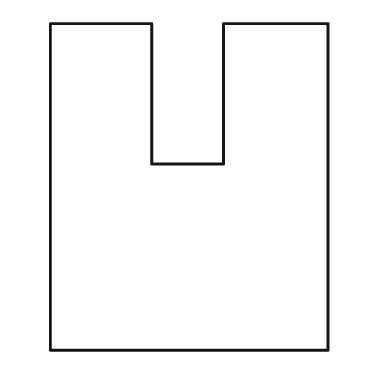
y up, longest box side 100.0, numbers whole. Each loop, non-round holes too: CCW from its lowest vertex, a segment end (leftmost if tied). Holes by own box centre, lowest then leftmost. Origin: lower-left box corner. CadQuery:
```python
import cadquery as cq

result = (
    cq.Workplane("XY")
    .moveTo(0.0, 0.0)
    .lineTo(85.0, 0.0)
    .lineTo(85.0, 100.0)
    .lineTo(53.0, 100.0)
    .lineTo(53.0, 57.0)
    .lineTo(31.0, 57.0)
    .lineTo(31.0, 100.0)
    .lineTo(0.0, 100.0)
    .close()
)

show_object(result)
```